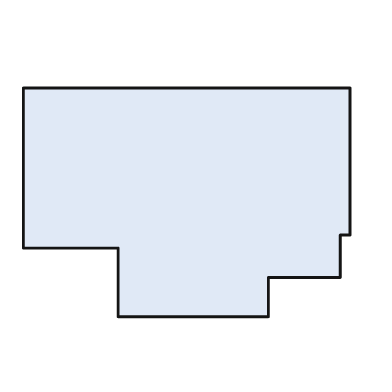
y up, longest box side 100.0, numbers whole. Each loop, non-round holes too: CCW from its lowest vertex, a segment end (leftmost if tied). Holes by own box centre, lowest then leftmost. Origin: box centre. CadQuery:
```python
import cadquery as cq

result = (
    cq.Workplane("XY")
    .moveTo(-21.0, -35.0)
    .lineTo(25.0, -35.0)
    .lineTo(25.0, -23.0)
    .lineTo(47.0, -23.0)
    .lineTo(47.0, -10.0)
    .lineTo(50.0, -10.0)
    .lineTo(50.0, 35.0)
    .lineTo(-50.0, 35.0)
    .lineTo(-50.0, -14.0)
    .lineTo(-21.0, -14.0)
    .close()
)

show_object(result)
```